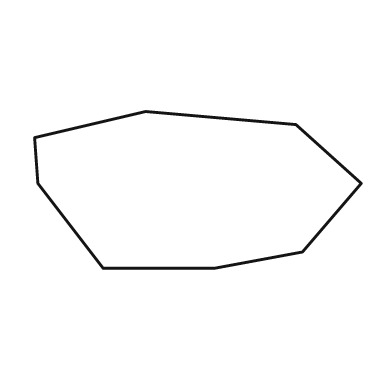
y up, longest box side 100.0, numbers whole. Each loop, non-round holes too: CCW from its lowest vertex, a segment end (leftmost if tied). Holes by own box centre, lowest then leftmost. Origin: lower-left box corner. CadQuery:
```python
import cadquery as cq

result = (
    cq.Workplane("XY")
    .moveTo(21.0, 0.0)
    .lineTo(55.0, 0.0)
    .lineTo(82.0, 5.0)
    .lineTo(100.0, 26.0)
    .lineTo(80.0, 44.0)
    .lineTo(34.0, 48.0)
    .lineTo(0.0, 40.0)
    .lineTo(1.0, 26.0)
    .close()
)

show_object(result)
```